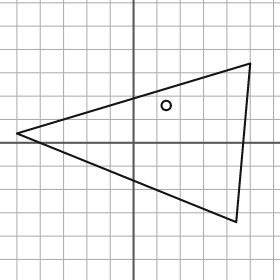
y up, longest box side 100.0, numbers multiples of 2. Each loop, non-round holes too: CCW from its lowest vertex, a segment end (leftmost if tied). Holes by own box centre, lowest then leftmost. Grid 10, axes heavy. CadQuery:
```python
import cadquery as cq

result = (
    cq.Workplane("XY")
    .moveTo(44.0, -34.0)
    .lineTo(50.0, 34.0)
    .lineTo(-50.0, 4.0)
    .close()
    .moveTo(14.0, 16.0)
    .circle(2.0)
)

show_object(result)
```